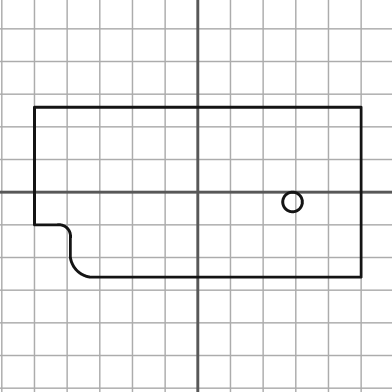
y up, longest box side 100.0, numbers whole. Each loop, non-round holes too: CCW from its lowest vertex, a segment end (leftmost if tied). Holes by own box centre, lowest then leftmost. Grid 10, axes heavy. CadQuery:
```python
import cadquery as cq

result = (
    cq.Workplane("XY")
    .moveTo(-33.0, -26.0)
    .lineTo(50.0, -26.0)
    .lineTo(50.0, 26.0)
    .lineTo(-50.0, 26.0)
    .lineTo(-50.0, -10.0)
    .lineTo(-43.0, -10.0)
    .threePointArc((-40.0, -11.0), (-39.0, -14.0))
    .lineTo(-39.0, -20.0)
    .threePointArc((-37.0, -24.0), (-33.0, -26.0))
    .close()
    .moveTo(29.0, -3.0)
    .circle(3.0)
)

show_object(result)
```